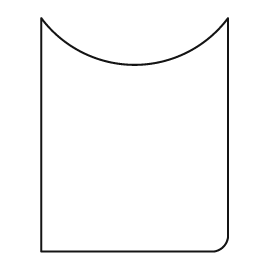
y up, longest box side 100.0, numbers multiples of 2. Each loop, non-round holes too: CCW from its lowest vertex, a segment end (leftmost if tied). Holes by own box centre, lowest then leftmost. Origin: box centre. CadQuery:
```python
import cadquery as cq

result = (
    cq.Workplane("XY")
    .moveTo(-40.0, -50.0)
    .lineTo(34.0, -50.0)
    .threePointArc((38.0, -48.0), (40.0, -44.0))
    .lineTo(40.0, 50.0)
    .threePointArc((0.0, 30.0), (-40.0, 50.0))
    .close()
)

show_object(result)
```